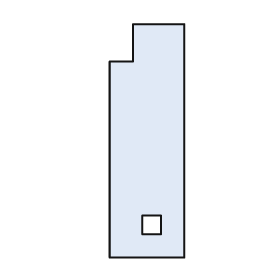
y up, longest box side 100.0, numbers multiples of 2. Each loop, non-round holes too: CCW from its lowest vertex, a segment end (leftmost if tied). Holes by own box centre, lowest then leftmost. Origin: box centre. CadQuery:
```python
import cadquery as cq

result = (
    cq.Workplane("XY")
    .moveTo(-16.0, -50.0)
    .lineTo(16.0, -50.0)
    .lineTo(16.0, 50.0)
    .lineTo(-6.0, 50.0)
    .lineTo(-6.0, 34.0)
    .lineTo(-16.0, 34.0)
    .close()
    .moveTo(-2.0, -40.0)
    .lineTo(6.0, -40.0)
    .lineTo(6.0, -32.0)
    .lineTo(-2.0, -32.0)
    .close()
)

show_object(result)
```